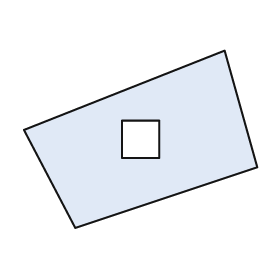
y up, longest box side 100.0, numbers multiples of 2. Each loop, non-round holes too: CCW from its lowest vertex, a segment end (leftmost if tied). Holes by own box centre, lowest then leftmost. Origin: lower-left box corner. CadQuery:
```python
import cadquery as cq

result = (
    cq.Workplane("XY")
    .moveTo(22.0, 0.0)
    .lineTo(100.0, 26.0)
    .lineTo(86.0, 76.0)
    .lineTo(0.0, 42.0)
    .close()
    .moveTo(42.0, 30.0)
    .lineTo(58.0, 30.0)
    .lineTo(58.0, 46.0)
    .lineTo(42.0, 46.0)
    .close()
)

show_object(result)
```